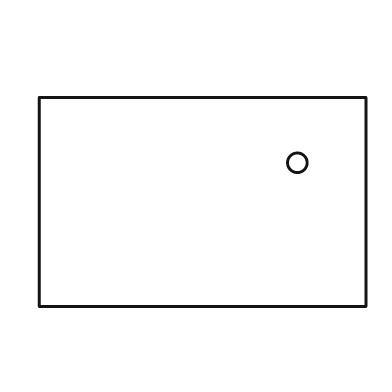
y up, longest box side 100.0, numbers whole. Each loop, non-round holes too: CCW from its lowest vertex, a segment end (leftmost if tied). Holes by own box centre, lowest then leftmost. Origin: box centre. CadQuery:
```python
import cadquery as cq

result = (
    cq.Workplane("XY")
    .moveTo(-50.0, -32.0)
    .lineTo(50.0, -32.0)
    .lineTo(50.0, 32.0)
    .lineTo(-50.0, 32.0)
    .close()
    .moveTo(29.0, 12.0)
    .circle(3.0)
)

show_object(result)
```